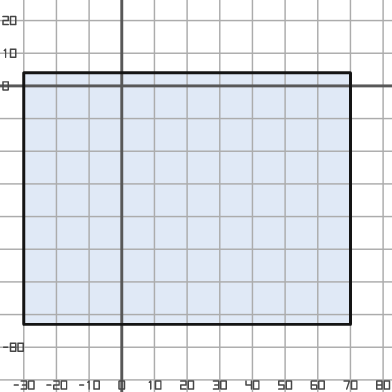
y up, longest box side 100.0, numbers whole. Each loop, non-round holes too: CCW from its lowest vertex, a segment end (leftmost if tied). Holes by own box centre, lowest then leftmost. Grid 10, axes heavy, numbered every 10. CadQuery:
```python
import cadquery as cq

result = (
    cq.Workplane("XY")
    .moveTo(-30.0, -73.0)
    .lineTo(70.0, -73.0)
    .lineTo(70.0, 4.0)
    .lineTo(-30.0, 4.0)
    .close()
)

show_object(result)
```